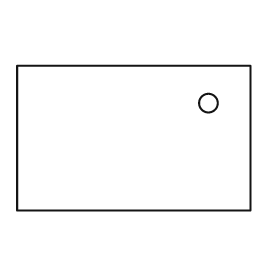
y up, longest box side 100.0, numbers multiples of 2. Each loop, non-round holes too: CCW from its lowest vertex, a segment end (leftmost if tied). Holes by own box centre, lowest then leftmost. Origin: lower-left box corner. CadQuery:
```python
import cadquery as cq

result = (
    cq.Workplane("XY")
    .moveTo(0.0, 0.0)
    .lineTo(100.0, 0.0)
    .lineTo(100.0, 62.0)
    .lineTo(0.0, 62.0)
    .close()
    .moveTo(82.0, 46.0)
    .circle(4.0)
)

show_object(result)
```